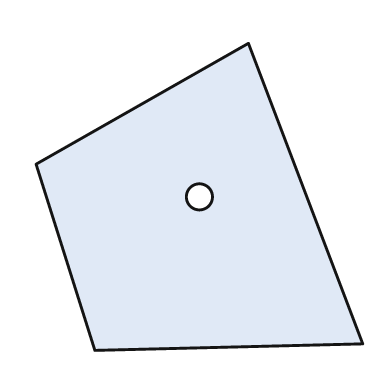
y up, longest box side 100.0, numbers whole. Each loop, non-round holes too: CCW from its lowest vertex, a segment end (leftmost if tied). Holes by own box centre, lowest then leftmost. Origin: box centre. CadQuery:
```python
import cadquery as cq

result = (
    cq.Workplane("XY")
    .moveTo(-32.0, -47.0)
    .lineTo(50.0, -45.0)
    .lineTo(15.0, 47.0)
    .lineTo(-50.0, 10.0)
    .close()
    .moveTo(0.0, 0.0)
    .circle(4.0)
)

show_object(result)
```